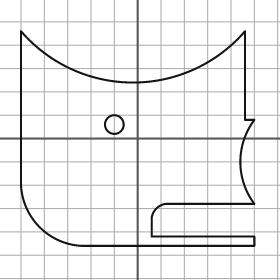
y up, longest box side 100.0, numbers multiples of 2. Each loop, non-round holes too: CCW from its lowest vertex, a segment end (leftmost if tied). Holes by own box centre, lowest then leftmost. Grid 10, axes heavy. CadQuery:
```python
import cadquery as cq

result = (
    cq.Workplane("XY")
    .moveTo(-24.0, -46.0)
    .lineTo(50.0, -46.0)
    .lineTo(50.0, -42.0)
    .lineTo(6.0, -42.0)
    .lineTo(6.0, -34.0)
    .threePointArc((8.0, -30.0), (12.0, -28.0))
    .lineTo(50.0, -28.0)
    .threePointArc((44.0, -10.0), (50.0, 8.0))
    .lineTo(46.0, 8.0)
    .lineTo(46.0, 46.0)
    .threePointArc((-2.0, 24.0), (-50.0, 46.0))
    .lineTo(-50.0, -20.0)
    .threePointArc((-42.0, -38.0), (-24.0, -46.0))
    .close()
    .moveTo(-10.0, 6.0)
    .circle(4.0)
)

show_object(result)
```